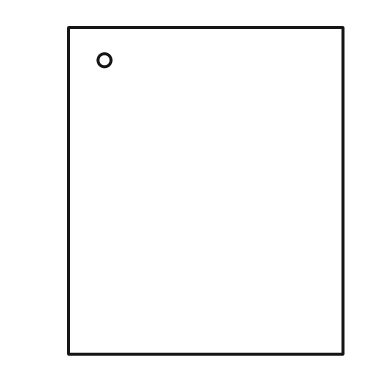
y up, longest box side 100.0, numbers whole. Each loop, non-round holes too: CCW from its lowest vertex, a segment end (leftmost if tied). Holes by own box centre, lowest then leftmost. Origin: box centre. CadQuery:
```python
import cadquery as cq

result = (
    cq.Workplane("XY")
    .moveTo(-42.0, -50.0)
    .lineTo(42.0, -50.0)
    .lineTo(42.0, 50.0)
    .lineTo(-42.0, 50.0)
    .close()
    .moveTo(-31.0, 40.0)
    .circle(2.0)
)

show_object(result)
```